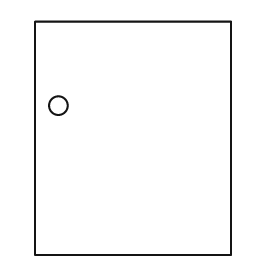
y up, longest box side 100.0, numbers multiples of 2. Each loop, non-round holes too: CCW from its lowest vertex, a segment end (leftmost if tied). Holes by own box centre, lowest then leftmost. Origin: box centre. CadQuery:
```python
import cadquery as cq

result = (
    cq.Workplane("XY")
    .moveTo(-42.0, -50.0)
    .lineTo(42.0, -50.0)
    .lineTo(42.0, 50.0)
    .lineTo(-42.0, 50.0)
    .close()
    .moveTo(-32.0, 14.0)
    .circle(4.0)
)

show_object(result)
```